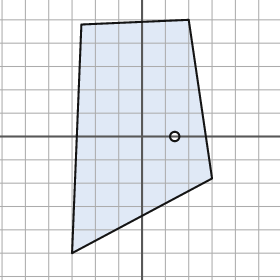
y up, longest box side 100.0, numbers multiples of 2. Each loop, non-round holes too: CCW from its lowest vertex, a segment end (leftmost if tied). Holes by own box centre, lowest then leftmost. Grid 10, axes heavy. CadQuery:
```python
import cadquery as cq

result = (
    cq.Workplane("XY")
    .moveTo(-30.0, -50.0)
    .lineTo(30.0, -18.0)
    .lineTo(20.0, 50.0)
    .lineTo(-26.0, 48.0)
    .close()
    .moveTo(14.0, 0.0)
    .circle(2.0)
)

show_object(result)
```